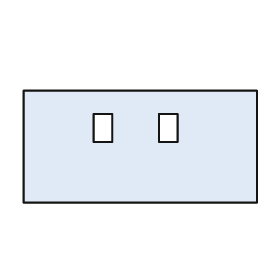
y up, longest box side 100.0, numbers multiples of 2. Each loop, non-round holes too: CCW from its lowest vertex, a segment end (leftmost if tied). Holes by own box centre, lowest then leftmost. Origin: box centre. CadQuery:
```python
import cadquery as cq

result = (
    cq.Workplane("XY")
    .moveTo(-50.0, -24.0)
    .lineTo(50.0, -24.0)
    .lineTo(50.0, 24.0)
    .lineTo(-50.0, 24.0)
    .close()
    .moveTo(-20.0, 2.0)
    .lineTo(-12.0, 2.0)
    .lineTo(-12.0, 14.0)
    .lineTo(-20.0, 14.0)
    .close()
    .moveTo(8.0, 2.0)
    .lineTo(16.0, 2.0)
    .lineTo(16.0, 14.0)
    .lineTo(8.0, 14.0)
    .close()
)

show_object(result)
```